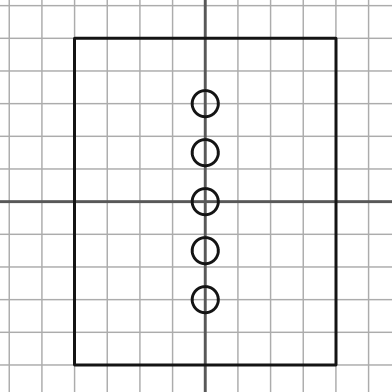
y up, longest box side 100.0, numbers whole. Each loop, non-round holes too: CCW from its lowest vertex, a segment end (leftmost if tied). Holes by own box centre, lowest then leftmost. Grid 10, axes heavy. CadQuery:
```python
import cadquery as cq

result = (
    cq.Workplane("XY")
    .moveTo(-40.0, -50.0)
    .lineTo(40.0, -50.0)
    .lineTo(40.0, 50.0)
    .lineTo(-40.0, 50.0)
    .close()
    .moveTo(0.0, -30.0)
    .circle(4.0)
    .moveTo(0.0, -15.0)
    .circle(4.0)
    .moveTo(0.0, 0.0)
    .circle(4.0)
    .moveTo(0.0, 15.0)
    .circle(4.0)
    .moveTo(0.0, 30.0)
    .circle(4.0)
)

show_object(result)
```